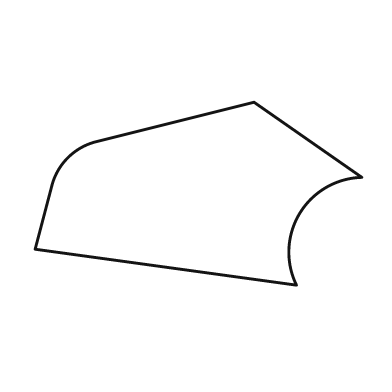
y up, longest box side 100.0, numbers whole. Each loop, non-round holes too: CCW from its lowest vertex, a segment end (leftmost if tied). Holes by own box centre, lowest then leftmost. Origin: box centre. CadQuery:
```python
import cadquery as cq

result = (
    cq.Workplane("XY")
    .moveTo(30.0, -28.0)
    .threePointArc((31.0, -6.0), (50.0, 5.0))
    .lineTo(17.0, 28.0)
    .lineTo(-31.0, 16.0)
    .threePointArc((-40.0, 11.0), (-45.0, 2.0))
    .lineTo(-50.0, -17.0)
    .close()
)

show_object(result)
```